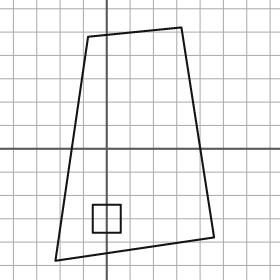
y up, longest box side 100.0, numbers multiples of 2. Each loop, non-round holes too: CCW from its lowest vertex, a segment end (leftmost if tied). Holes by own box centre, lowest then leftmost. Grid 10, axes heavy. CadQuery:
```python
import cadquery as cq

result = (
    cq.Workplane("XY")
    .moveTo(-22.0, -48.0)
    .lineTo(46.0, -38.0)
    .lineTo(32.0, 52.0)
    .lineTo(-8.0, 48.0)
    .close()
    .moveTo(-6.0, -36.0)
    .lineTo(6.0, -36.0)
    .lineTo(6.0, -24.0)
    .lineTo(-6.0, -24.0)
    .close()
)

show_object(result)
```